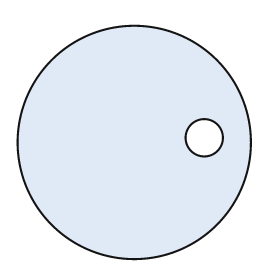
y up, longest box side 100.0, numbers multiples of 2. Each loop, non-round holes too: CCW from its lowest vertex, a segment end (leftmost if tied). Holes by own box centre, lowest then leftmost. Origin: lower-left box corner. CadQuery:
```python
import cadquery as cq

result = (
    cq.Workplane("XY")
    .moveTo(50.0, 50.0)
    .circle(50.0)
    .moveTo(80.0, 52.0)
    .circle(8.0)
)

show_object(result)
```